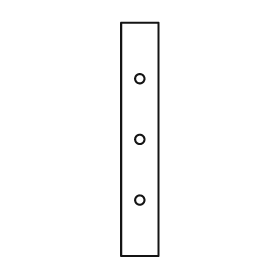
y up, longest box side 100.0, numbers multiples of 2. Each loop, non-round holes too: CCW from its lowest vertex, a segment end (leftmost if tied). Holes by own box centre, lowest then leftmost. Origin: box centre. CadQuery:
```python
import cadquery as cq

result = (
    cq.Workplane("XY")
    .moveTo(-8.0, -50.0)
    .lineTo(8.0, -50.0)
    .lineTo(8.0, 50.0)
    .lineTo(-8.0, 50.0)
    .close()
    .moveTo(0.0, -26.0)
    .circle(2.0)
    .moveTo(0.0, 0.0)
    .circle(2.0)
    .moveTo(0.0, 26.0)
    .circle(2.0)
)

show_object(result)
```